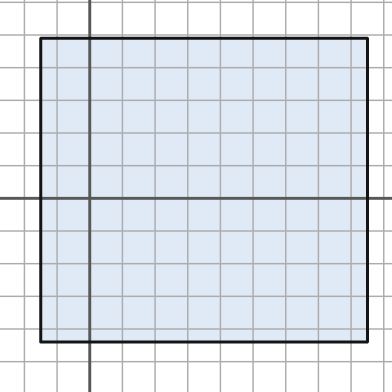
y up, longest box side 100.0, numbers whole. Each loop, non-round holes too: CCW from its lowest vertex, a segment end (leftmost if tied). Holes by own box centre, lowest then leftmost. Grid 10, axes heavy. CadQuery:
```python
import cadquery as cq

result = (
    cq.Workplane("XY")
    .moveTo(-15.0, -44.0)
    .lineTo(85.0, -44.0)
    .lineTo(85.0, 49.0)
    .lineTo(-15.0, 49.0)
    .close()
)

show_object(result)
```